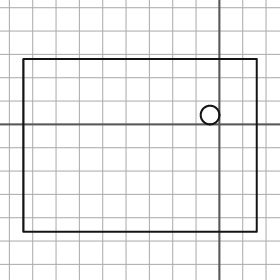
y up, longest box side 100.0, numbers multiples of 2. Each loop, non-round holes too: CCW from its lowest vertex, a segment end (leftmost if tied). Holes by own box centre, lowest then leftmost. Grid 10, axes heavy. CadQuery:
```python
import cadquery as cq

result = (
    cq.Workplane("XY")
    .moveTo(-84.0, -46.0)
    .lineTo(16.0, -46.0)
    .lineTo(16.0, 28.0)
    .lineTo(-84.0, 28.0)
    .close()
    .moveTo(-4.0, 4.0)
    .circle(4.0)
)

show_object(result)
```